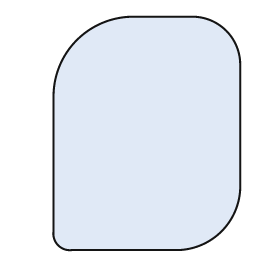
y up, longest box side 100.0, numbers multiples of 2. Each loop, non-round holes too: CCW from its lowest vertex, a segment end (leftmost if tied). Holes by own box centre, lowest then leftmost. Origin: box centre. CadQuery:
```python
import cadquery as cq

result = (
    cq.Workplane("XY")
    .moveTo(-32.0, -50.0)
    .lineTo(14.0, -50.0)
    .threePointArc((32.0, -42.0), (40.0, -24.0))
    .lineTo(40.0, 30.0)
    .threePointArc((34.0, 44.0), (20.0, 50.0))
    .lineTo(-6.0, 50.0)
    .threePointArc((-30.0, 40.0), (-40.0, 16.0))
    .lineTo(-40.0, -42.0)
    .threePointArc((-38.0, -48.0), (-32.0, -50.0))
    .close()
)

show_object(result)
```